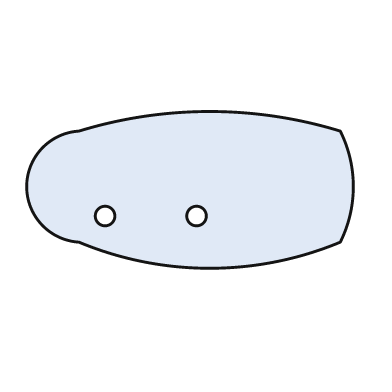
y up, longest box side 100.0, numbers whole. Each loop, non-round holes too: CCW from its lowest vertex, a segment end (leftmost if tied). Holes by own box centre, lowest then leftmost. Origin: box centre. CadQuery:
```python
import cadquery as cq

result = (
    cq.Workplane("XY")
    .moveTo(-34.0, -16.0)
    .threePointArc((6.0, -24.0), (46.0, -16.0))
    .threePointArc((50.0, 1.0), (46.0, 18.0))
    .threePointArc((6.0, 24.0), (-34.0, 18.0))
    .threePointArc((-50.0, 1.0), (-34.0, -16.0))
    .close()
    .moveTo(-26.0, -8.0)
    .circle(3.0)
    .moveTo(2.0, -8.0)
    .circle(3.0)
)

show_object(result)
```